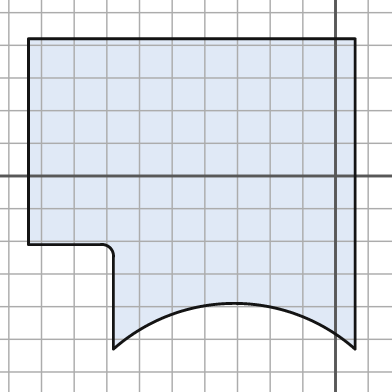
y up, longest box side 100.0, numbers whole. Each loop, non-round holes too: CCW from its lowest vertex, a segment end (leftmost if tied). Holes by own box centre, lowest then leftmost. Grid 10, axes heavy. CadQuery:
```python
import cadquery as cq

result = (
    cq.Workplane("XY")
    .moveTo(-68.0, -53.0)
    .threePointArc((-31.0, -39.0), (6.0, -53.0))
    .lineTo(6.0, 42.0)
    .lineTo(-94.0, 42.0)
    .lineTo(-94.0, -21.0)
    .lineTo(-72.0, -21.0)
    .threePointArc((-69.0, -22.0), (-68.0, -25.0))
    .close()
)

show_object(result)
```